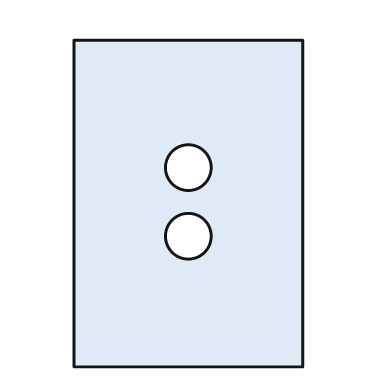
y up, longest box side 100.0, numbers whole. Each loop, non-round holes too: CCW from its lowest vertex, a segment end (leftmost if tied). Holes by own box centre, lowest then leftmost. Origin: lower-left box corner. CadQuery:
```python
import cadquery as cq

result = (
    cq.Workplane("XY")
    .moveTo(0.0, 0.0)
    .lineTo(70.0, 0.0)
    .lineTo(70.0, 100.0)
    .lineTo(0.0, 100.0)
    .close()
    .moveTo(35.0, 40.0)
    .circle(7.0)
    .moveTo(35.0, 61.0)
    .circle(7.0)
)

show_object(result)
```